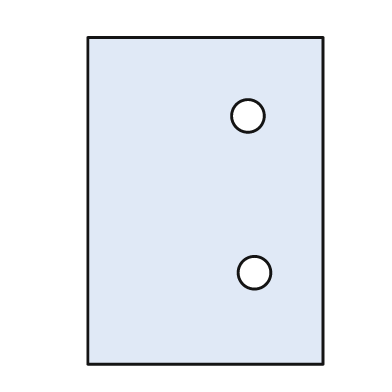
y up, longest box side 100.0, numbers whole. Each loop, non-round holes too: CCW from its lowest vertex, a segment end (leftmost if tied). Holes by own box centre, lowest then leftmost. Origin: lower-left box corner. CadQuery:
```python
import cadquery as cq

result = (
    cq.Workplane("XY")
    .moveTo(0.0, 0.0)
    .lineTo(72.0, 0.0)
    .lineTo(72.0, 100.0)
    .lineTo(0.0, 100.0)
    .close()
    .moveTo(51.0, 28.0)
    .circle(5.0)
    .moveTo(49.0, 76.0)
    .circle(5.0)
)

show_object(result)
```